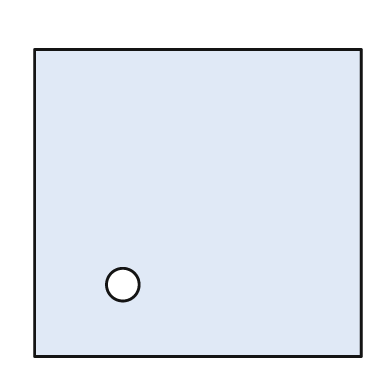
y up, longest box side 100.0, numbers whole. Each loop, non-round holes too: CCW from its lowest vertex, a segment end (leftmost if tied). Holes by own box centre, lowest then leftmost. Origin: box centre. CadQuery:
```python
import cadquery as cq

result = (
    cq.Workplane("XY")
    .moveTo(-50.0, -47.0)
    .lineTo(50.0, -47.0)
    .lineTo(50.0, 47.0)
    .lineTo(-50.0, 47.0)
    .close()
    .moveTo(-23.0, -25.0)
    .circle(5.0)
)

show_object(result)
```